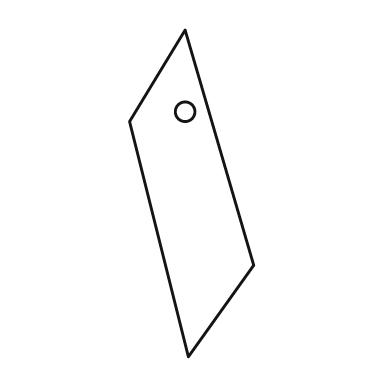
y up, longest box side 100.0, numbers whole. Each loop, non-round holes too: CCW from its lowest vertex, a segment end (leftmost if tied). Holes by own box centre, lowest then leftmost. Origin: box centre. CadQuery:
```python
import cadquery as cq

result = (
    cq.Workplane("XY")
    .moveTo(-1.0, -50.0)
    .lineTo(19.0, -22.0)
    .lineTo(-2.0, 50.0)
    .lineTo(-19.0, 22.0)
    .close()
    .moveTo(-2.0, 25.0)
    .circle(3.0)
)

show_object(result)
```